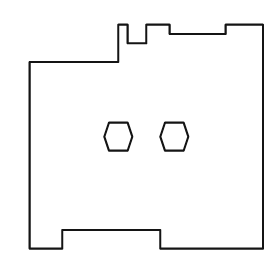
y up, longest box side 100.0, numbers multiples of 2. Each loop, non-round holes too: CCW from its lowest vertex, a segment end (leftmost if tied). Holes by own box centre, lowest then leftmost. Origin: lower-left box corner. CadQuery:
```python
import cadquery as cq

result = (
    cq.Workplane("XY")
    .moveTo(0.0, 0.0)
    .lineTo(14.0, 0.0)
    .lineTo(14.0, 8.0)
    .lineTo(56.0, 8.0)
    .lineTo(56.0, 0.0)
    .lineTo(100.0, 0.0)
    .lineTo(100.0, 96.0)
    .lineTo(84.0, 96.0)
    .lineTo(84.0, 92.0)
    .lineTo(60.0, 92.0)
    .lineTo(60.0, 96.0)
    .lineTo(50.0, 96.0)
    .lineTo(50.0, 88.0)
    .lineTo(42.0, 88.0)
    .lineTo(42.0, 96.0)
    .lineTo(38.0, 96.0)
    .lineTo(38.0, 80.0)
    .lineTo(0.0, 80.0)
    .close()
    .moveTo(34.0, 42.0)
    .lineTo(42.0, 42.0)
    .lineTo(44.0, 48.0)
    .lineTo(42.0, 54.0)
    .lineTo(34.0, 54.0)
    .lineTo(32.0, 48.0)
    .close()
    .moveTo(58.0, 42.0)
    .lineTo(66.0, 42.0)
    .lineTo(68.0, 48.0)
    .lineTo(66.0, 54.0)
    .lineTo(58.0, 54.0)
    .lineTo(56.0, 48.0)
    .close()
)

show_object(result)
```